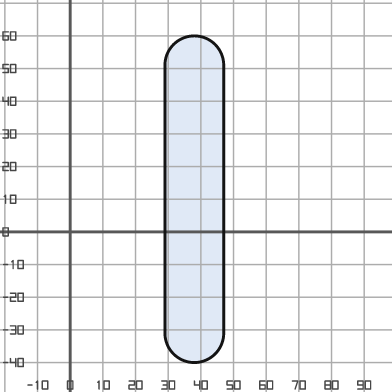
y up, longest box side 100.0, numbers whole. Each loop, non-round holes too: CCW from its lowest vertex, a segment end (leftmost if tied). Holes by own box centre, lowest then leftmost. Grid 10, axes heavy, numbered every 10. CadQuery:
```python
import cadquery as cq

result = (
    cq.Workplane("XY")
    .moveTo(29.0, -31.0)
    .threePointArc((38.0, -40.0), (47.0, -31.0))
    .lineTo(47.0, 51.0)
    .threePointArc((38.0, 60.0), (29.0, 51.0))
    .close()
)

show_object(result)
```